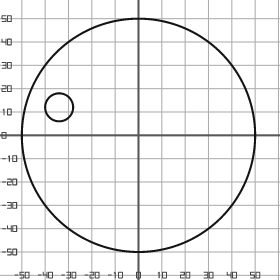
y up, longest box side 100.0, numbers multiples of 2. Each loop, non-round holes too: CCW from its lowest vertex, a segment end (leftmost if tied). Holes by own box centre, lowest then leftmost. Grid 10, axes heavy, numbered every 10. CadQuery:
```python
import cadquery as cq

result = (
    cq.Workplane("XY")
    .moveTo(0.0, 0.0)
    .circle(50.0)
    .moveTo(-34.0, 12.0)
    .circle(6.0)
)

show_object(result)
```